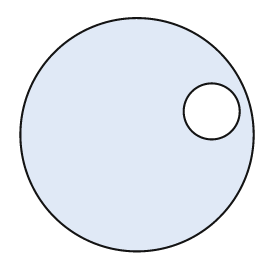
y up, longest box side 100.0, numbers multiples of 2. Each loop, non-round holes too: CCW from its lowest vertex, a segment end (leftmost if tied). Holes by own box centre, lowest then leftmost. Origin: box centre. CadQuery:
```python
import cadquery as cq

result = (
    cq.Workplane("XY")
    .moveTo(0.0, 0.0)
    .circle(50.0)
    .moveTo(32.0, 10.0)
    .circle(12.0)
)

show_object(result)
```